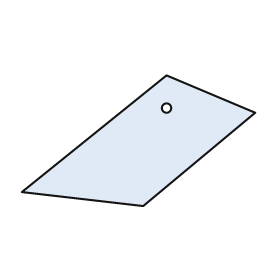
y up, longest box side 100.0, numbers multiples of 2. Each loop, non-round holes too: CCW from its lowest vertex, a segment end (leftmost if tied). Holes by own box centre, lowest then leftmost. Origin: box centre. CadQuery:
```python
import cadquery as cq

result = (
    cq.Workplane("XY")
    .moveTo(2.0, -28.0)
    .lineTo(50.0, 12.0)
    .lineTo(12.0, 28.0)
    .lineTo(-50.0, -22.0)
    .close()
    .moveTo(12.0, 14.0)
    .circle(2.0)
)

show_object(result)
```